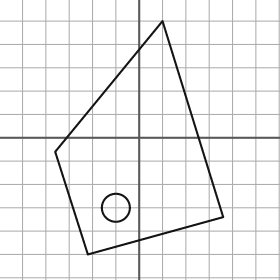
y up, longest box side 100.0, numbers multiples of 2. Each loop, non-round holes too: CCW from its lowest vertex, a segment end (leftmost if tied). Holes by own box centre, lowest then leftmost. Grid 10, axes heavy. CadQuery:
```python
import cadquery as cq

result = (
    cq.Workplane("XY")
    .moveTo(-22.0, -50.0)
    .lineTo(36.0, -34.0)
    .lineTo(10.0, 50.0)
    .lineTo(-36.0, -6.0)
    .close()
    .moveTo(-10.0, -30.0)
    .circle(6.0)
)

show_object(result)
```